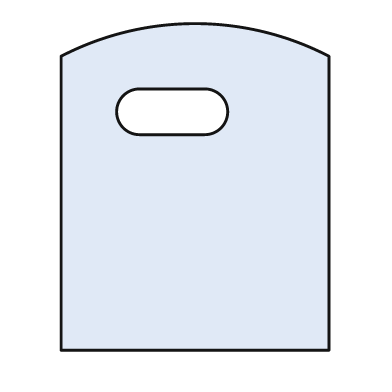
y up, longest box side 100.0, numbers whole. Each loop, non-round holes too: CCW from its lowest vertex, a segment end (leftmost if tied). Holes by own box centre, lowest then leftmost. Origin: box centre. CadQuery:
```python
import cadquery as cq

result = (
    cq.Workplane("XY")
    .moveTo(-41.0, -50.0)
    .lineTo(41.0, -50.0)
    .lineTo(41.0, 40.0)
    .threePointArc((0.0, 50.0), (-41.0, 40.0))
    .close()
    .moveTo(-17.0, 16.0)
    .lineTo(3.0, 16.0)
    .threePointArc((10.0, 23.0), (3.0, 30.0))
    .lineTo(-17.0, 30.0)
    .threePointArc((-24.0, 23.0), (-17.0, 16.0))
    .close()
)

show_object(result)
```